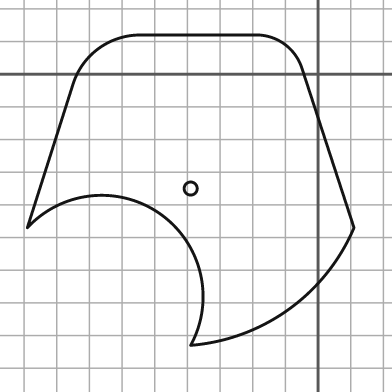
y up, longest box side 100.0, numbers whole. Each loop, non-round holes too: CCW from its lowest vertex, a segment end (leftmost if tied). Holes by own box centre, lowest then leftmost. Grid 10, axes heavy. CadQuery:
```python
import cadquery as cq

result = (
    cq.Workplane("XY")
    .moveTo(-39.0, -83.0)
    .threePointArc((-9.0, -72.0), (11.0, -47.0))
    .lineTo(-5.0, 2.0)
    .threePointArc((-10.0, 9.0), (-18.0, 12.0))
    .lineTo(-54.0, 12.0)
    .threePointArc((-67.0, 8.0), (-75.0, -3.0))
    .lineTo(-89.0, -47.0)
    .threePointArc((-48.0, -43.0), (-39.0, -83.0))
    .close()
    .moveTo(-39.0, -35.0)
    .circle(2.0)
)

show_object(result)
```